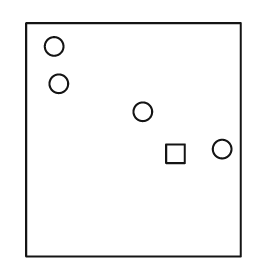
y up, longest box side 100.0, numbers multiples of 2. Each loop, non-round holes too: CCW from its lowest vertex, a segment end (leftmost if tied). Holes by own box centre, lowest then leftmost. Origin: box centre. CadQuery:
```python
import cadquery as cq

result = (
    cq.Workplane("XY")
    .moveTo(-46.0, -50.0)
    .lineTo(46.0, -50.0)
    .lineTo(46.0, 50.0)
    .lineTo(-46.0, 50.0)
    .close()
    .moveTo(14.0, -10.0)
    .lineTo(22.0, -10.0)
    .lineTo(22.0, -2.0)
    .lineTo(14.0, -2.0)
    .close()
    .moveTo(38.0, -4.0)
    .circle(4.0)
    .moveTo(4.0, 12.0)
    .circle(4.0)
    .moveTo(-32.0, 24.0)
    .circle(4.0)
    .moveTo(-34.0, 40.0)
    .circle(4.0)
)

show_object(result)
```